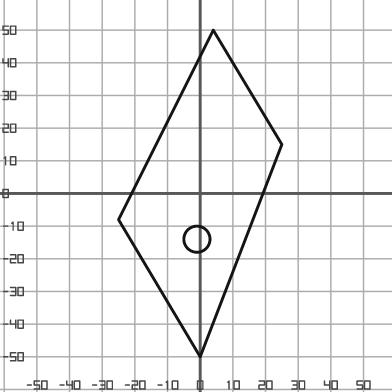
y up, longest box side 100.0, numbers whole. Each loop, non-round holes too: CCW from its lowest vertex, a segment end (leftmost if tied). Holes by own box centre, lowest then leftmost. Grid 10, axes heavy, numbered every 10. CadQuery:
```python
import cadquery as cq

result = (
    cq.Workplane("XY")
    .moveTo(0.0, -50.0)
    .lineTo(25.0, 15.0)
    .lineTo(4.0, 50.0)
    .lineTo(-25.0, -8.0)
    .close()
    .moveTo(-1.0, -14.0)
    .circle(4.0)
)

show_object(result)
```